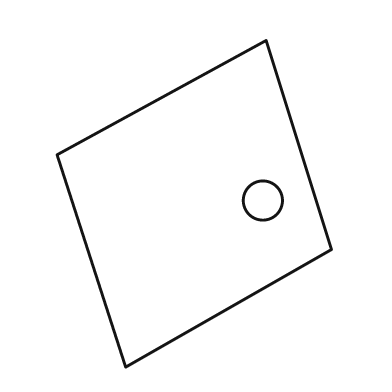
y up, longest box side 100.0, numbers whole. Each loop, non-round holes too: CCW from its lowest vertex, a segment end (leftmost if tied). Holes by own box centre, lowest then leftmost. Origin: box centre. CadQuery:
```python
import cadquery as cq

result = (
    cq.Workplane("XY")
    .moveTo(-21.0, -50.0)
    .lineTo(42.0, -14.0)
    .lineTo(22.0, 50.0)
    .lineTo(-42.0, 15.0)
    .close()
    .moveTo(21.0, 1.0)
    .circle(6.0)
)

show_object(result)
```